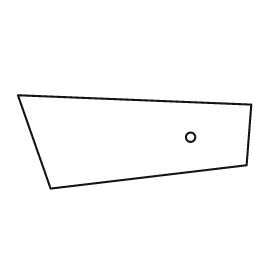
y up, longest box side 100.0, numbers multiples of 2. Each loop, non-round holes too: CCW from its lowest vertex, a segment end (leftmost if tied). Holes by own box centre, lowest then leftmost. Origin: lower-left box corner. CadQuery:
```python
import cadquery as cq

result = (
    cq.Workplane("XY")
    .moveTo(14.0, 0.0)
    .lineTo(98.0, 10.0)
    .lineTo(100.0, 36.0)
    .lineTo(0.0, 40.0)
    .close()
    .moveTo(74.0, 22.0)
    .circle(2.0)
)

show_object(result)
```